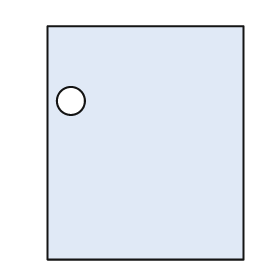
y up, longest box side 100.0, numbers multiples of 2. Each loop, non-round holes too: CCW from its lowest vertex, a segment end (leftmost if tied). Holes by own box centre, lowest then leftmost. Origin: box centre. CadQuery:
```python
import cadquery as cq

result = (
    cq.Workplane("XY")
    .moveTo(-42.0, -50.0)
    .lineTo(42.0, -50.0)
    .lineTo(42.0, 50.0)
    .lineTo(-42.0, 50.0)
    .close()
    .moveTo(-32.0, 18.0)
    .circle(6.0)
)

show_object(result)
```